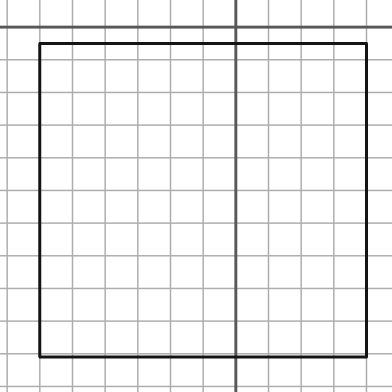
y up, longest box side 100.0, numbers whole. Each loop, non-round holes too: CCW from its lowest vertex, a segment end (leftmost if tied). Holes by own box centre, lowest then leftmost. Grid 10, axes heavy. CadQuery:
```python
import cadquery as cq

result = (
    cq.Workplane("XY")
    .moveTo(-60.0, -101.0)
    .lineTo(40.0, -101.0)
    .lineTo(40.0, -5.0)
    .lineTo(-60.0, -5.0)
    .close()
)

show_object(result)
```